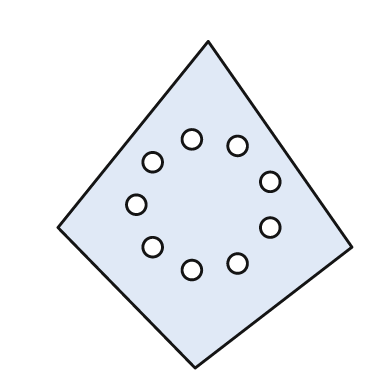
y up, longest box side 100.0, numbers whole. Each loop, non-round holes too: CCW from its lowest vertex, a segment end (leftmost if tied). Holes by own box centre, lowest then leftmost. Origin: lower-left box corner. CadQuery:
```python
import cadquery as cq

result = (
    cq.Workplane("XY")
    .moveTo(42.0, 0.0)
    .lineTo(90.0, 37.0)
    .lineTo(46.0, 100.0)
    .lineTo(0.0, 43.0)
    .close()
    .moveTo(41.0, 30.0)
    .circle(3.0)
    .moveTo(55.0, 32.0)
    .circle(3.0)
    .moveTo(29.0, 37.0)
    .circle(3.0)
    .moveTo(65.0, 43.0)
    .circle(3.0)
    .moveTo(24.0, 50.0)
    .circle(3.0)
    .moveTo(65.0, 57.0)
    .circle(3.0)
    .moveTo(29.0, 63.0)
    .circle(3.0)
    .moveTo(55.0, 68.0)
    .circle(3.0)
    .moveTo(41.0, 70.0)
    .circle(3.0)
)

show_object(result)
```